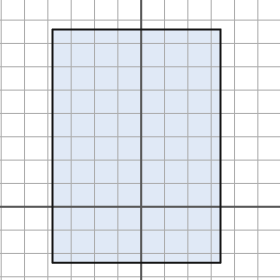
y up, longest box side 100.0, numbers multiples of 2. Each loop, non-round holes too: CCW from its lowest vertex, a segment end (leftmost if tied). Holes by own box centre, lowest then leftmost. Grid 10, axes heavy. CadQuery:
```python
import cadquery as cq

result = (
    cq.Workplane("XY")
    .moveTo(-38.0, -24.0)
    .lineTo(34.0, -24.0)
    .lineTo(34.0, 76.0)
    .lineTo(-38.0, 76.0)
    .close()
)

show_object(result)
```